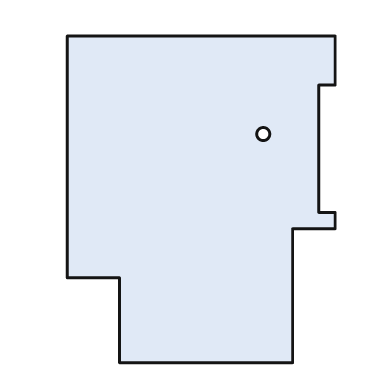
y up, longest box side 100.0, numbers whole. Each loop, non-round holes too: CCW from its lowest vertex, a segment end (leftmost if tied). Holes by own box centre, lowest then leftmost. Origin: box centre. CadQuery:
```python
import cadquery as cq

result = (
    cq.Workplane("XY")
    .moveTo(-25.0, -50.0)
    .lineTo(28.0, -50.0)
    .lineTo(28.0, -9.0)
    .lineTo(41.0, -9.0)
    .lineTo(41.0, -4.0)
    .lineTo(36.0, -4.0)
    .lineTo(36.0, 35.0)
    .lineTo(41.0, 35.0)
    .lineTo(41.0, 50.0)
    .lineTo(-41.0, 50.0)
    .lineTo(-41.0, -24.0)
    .lineTo(-25.0, -24.0)
    .close()
    .moveTo(19.0, 20.0)
    .circle(2.0)
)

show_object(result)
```